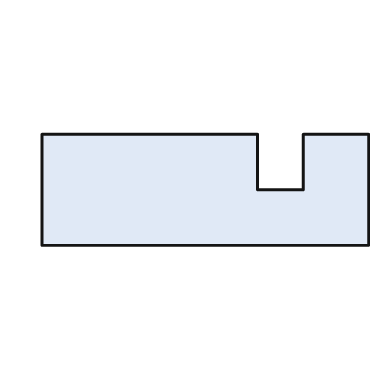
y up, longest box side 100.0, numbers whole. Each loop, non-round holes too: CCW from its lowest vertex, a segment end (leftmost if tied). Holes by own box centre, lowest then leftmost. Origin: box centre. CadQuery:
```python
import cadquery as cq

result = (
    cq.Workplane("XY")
    .moveTo(-50.0, -17.0)
    .lineTo(50.0, -17.0)
    .lineTo(50.0, 17.0)
    .lineTo(30.0, 17.0)
    .lineTo(30.0, 0.0)
    .lineTo(16.0, 0.0)
    .lineTo(16.0, 17.0)
    .lineTo(-50.0, 17.0)
    .close()
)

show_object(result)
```